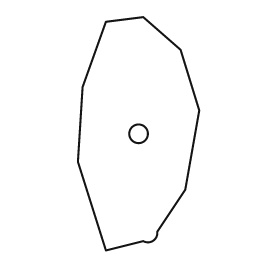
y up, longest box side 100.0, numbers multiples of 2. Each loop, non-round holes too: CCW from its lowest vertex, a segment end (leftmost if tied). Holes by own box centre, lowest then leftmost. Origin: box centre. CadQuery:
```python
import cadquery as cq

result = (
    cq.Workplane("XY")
    .moveTo(-14.0, -50.0)
    .lineTo(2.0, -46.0)
    .threePointArc((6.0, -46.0), (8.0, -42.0))
    .lineTo(20.0, -24.0)
    .lineTo(26.0, 10.0)
    .lineTo(18.0, 36.0)
    .lineTo(2.0, 50.0)
    .lineTo(-14.0, 48.0)
    .lineTo(-24.0, 20.0)
    .lineTo(-26.0, -12.0)
    .close()
    .moveTo(0.0, 0.0)
    .circle(4.0)
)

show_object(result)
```